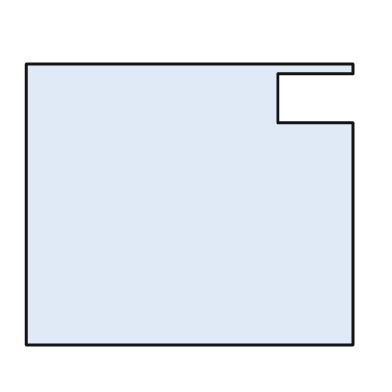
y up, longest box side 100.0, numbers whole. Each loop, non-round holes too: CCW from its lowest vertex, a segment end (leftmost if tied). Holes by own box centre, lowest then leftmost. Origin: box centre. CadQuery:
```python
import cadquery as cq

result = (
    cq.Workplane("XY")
    .moveTo(-50.0, -43.0)
    .lineTo(50.0, -43.0)
    .lineTo(50.0, 25.0)
    .lineTo(27.0, 25.0)
    .lineTo(27.0, 40.0)
    .lineTo(50.0, 40.0)
    .lineTo(50.0, 43.0)
    .lineTo(-50.0, 43.0)
    .close()
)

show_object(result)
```